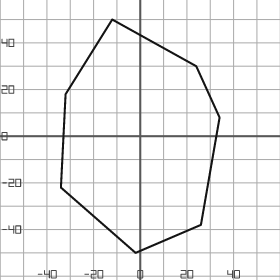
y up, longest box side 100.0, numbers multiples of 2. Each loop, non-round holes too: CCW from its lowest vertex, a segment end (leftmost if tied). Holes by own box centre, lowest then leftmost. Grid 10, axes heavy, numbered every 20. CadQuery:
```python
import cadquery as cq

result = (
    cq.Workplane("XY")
    .moveTo(-2.0, -50.0)
    .lineTo(26.0, -38.0)
    .lineTo(34.0, 8.0)
    .lineTo(24.0, 30.0)
    .lineTo(-12.0, 50.0)
    .lineTo(-32.0, 18.0)
    .lineTo(-34.0, -22.0)
    .close()
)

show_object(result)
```